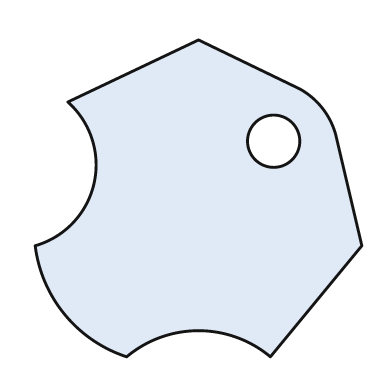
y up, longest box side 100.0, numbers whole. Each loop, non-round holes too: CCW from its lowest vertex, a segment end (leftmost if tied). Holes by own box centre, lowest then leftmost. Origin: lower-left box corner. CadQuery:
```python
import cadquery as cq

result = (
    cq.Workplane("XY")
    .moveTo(28.0, 0.0)
    .threePointArc((50.0, 8.0), (72.0, 0.0))
    .lineTo(100.0, 34.0)
    .lineTo(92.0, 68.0)
    .threePointArc((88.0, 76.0), (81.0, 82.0))
    .lineTo(50.0, 97.0)
    .lineTo(10.0, 78.0)
    .threePointArc((18.0, 53.0), (0.0, 34.0))
    .threePointArc((9.0, 13.0), (28.0, 0.0))
    .close()
    .moveTo(73.0, 66.0)
    .circle(8.0)
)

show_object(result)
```